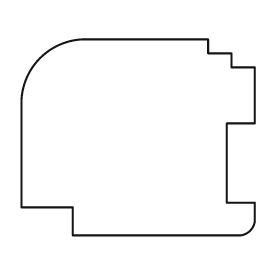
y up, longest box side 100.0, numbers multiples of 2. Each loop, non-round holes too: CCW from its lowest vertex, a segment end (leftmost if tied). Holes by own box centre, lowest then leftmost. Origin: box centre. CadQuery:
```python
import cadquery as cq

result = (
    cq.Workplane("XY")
    .moveTo(-28.0, -42.0)
    .lineTo(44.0, -42.0)
    .threePointArc((48.0, -40.0), (50.0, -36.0))
    .lineTo(50.0, -28.0)
    .lineTo(38.0, -28.0)
    .lineTo(38.0, 6.0)
    .lineTo(50.0, 6.0)
    .lineTo(50.0, 30.0)
    .lineTo(40.0, 30.0)
    .lineTo(40.0, 36.0)
    .lineTo(30.0, 36.0)
    .lineTo(30.0, 42.0)
    .lineTo(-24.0, 42.0)
    .threePointArc((-42.0, 34.0), (-50.0, 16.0))
    .lineTo(-50.0, -30.0)
    .lineTo(-28.0, -30.0)
    .close()
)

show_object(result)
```